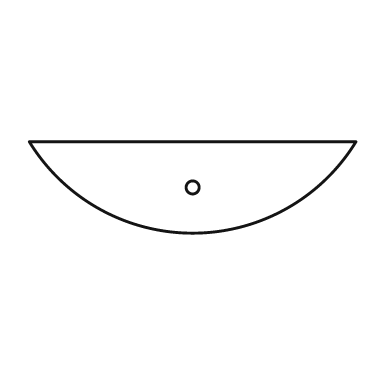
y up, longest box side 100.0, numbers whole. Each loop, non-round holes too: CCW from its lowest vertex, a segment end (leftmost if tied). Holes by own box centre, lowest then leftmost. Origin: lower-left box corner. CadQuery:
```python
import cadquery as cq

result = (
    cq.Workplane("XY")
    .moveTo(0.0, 28.0)
    .threePointArc((50.0, 0.0), (100.0, 28.0))
    .close()
    .moveTo(50.0, 14.0)
    .circle(2.0)
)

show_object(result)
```